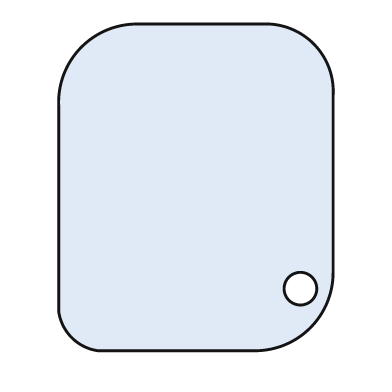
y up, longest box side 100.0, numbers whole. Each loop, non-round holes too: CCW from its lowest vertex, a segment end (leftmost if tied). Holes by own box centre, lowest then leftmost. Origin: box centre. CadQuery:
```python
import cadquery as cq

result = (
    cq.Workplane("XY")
    .moveTo(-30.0, -50.0)
    .lineTo(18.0, -50.0)
    .threePointArc((35.0, -43.0), (42.0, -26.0))
    .lineTo(42.0, 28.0)
    .threePointArc((36.0, 44.0), (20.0, 50.0))
    .lineTo(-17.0, 50.0)
    .threePointArc((-35.0, 43.0), (-42.0, 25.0))
    .lineTo(-42.0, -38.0)
    .threePointArc((-38.0, -46.0), (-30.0, -50.0))
    .close()
    .moveTo(32.0, -31.0)
    .circle(5.0)
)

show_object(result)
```